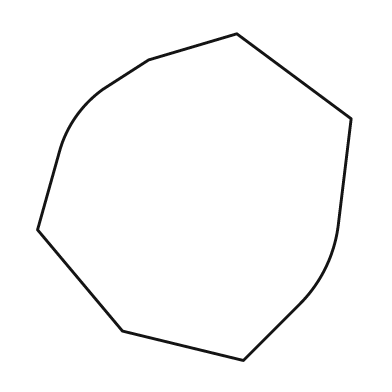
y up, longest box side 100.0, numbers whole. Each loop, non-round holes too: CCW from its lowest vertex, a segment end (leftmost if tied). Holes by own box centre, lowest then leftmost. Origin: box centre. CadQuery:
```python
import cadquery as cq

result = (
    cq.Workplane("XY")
    .moveTo(15.0, -50.0)
    .lineTo(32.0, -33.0)
    .threePointArc((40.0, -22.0), (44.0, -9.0))
    .lineTo(48.0, 24.0)
    .lineTo(13.0, 50.0)
    .lineTo(-14.0, 42.0)
    .lineTo(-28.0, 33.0)
    .threePointArc((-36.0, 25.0), (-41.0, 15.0))
    .lineTo(-48.0, -10.0)
    .lineTo(-22.0, -41.0)
    .close()
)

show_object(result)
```